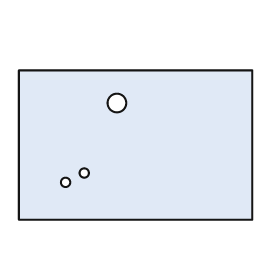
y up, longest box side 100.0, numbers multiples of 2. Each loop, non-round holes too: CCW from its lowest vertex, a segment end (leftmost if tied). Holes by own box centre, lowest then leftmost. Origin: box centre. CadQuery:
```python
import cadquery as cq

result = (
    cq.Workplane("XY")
    .moveTo(-50.0, -32.0)
    .lineTo(50.0, -32.0)
    .lineTo(50.0, 32.0)
    .lineTo(-50.0, 32.0)
    .close()
    .moveTo(-30.0, -16.0)
    .circle(2.0)
    .moveTo(-22.0, -12.0)
    .circle(2.0)
    .moveTo(-8.0, 18.0)
    .circle(4.0)
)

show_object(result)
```